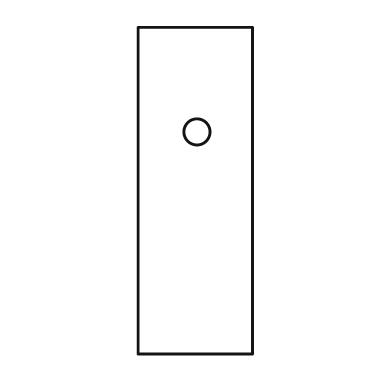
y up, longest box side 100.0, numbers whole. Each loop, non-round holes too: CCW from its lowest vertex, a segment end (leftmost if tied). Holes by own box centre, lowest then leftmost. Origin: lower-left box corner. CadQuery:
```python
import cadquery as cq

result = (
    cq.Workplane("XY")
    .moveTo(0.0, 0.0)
    .lineTo(35.0, 0.0)
    .lineTo(35.0, 100.0)
    .lineTo(0.0, 100.0)
    .close()
    .moveTo(18.0, 68.0)
    .circle(4.0)
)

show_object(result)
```